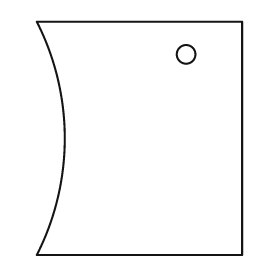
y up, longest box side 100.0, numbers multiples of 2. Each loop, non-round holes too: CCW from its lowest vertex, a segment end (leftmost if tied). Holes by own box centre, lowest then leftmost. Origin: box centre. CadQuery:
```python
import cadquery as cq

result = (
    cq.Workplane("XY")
    .moveTo(-44.0, -50.0)
    .lineTo(44.0, -50.0)
    .lineTo(44.0, 50.0)
    .lineTo(-44.0, 50.0)
    .threePointArc((-32.0, 0.0), (-44.0, -50.0))
    .close()
    .moveTo(20.0, 36.0)
    .circle(4.0)
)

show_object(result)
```